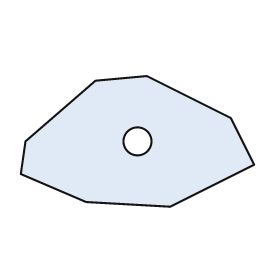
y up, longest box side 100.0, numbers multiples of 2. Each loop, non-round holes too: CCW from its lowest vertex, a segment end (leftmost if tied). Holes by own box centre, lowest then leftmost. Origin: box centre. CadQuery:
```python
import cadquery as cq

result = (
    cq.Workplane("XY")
    .moveTo(14.0, -28.0)
    .lineTo(50.0, -10.0)
    .lineTo(40.0, 10.0)
    .lineTo(4.0, 28.0)
    .lineTo(-18.0, 26.0)
    .lineTo(-48.0, 0.0)
    .lineTo(-50.0, -14.0)
    .lineTo(-22.0, -26.0)
    .close()
    .moveTo(0.0, 0.0)
    .circle(6.0)
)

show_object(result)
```